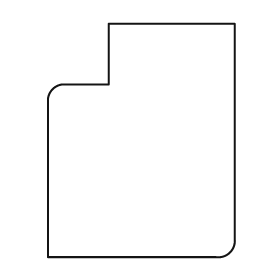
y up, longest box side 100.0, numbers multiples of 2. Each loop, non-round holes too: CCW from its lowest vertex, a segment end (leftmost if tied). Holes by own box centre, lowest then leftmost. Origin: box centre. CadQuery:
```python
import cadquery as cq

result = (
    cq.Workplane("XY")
    .moveTo(-40.0, -50.0)
    .lineTo(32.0, -50.0)
    .threePointArc((38.0, -48.0), (40.0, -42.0))
    .lineTo(40.0, 50.0)
    .lineTo(-14.0, 50.0)
    .lineTo(-14.0, 24.0)
    .lineTo(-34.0, 24.0)
    .threePointArc((-38.0, 22.0), (-40.0, 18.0))
    .close()
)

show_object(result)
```